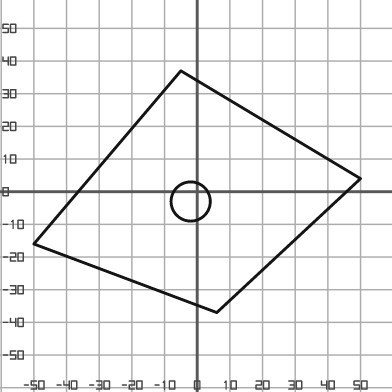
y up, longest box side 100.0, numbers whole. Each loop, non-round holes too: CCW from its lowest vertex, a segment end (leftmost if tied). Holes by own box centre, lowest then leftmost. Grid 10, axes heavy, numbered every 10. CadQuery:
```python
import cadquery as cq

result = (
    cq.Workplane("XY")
    .moveTo(6.0, -37.0)
    .lineTo(50.0, 4.0)
    .lineTo(-5.0, 37.0)
    .lineTo(-50.0, -16.0)
    .close()
    .moveTo(-2.0, -3.0)
    .circle(6.0)
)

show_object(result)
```